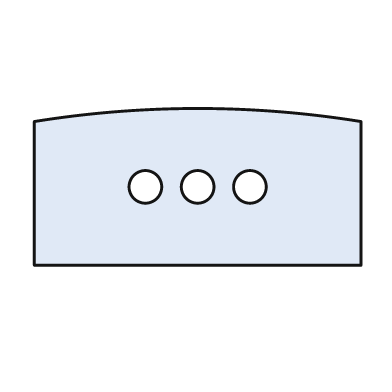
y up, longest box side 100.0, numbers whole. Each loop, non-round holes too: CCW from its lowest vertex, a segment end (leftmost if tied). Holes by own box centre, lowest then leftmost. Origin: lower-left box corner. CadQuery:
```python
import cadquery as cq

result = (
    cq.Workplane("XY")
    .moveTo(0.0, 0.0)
    .lineTo(100.0, 0.0)
    .lineTo(100.0, 44.0)
    .threePointArc((50.0, 48.0), (0.0, 44.0))
    .close()
    .moveTo(34.0, 24.0)
    .circle(5.0)
    .moveTo(50.0, 24.0)
    .circle(5.0)
    .moveTo(66.0, 24.0)
    .circle(5.0)
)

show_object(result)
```